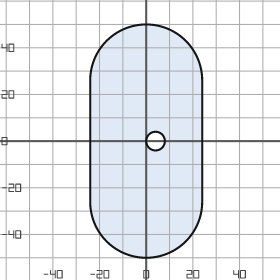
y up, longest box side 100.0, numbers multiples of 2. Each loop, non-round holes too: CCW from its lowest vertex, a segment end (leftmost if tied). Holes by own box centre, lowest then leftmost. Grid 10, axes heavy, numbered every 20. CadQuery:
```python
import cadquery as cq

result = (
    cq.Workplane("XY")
    .moveTo(-24.0, -26.0)
    .threePointArc((0.0, -50.0), (24.0, -26.0))
    .lineTo(24.0, 26.0)
    .threePointArc((0.0, 50.0), (-24.0, 26.0))
    .close()
    .moveTo(4.0, 0.0)
    .circle(4.0)
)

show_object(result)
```